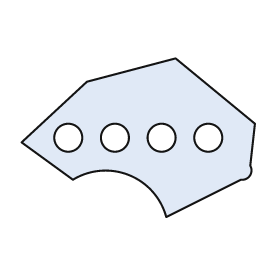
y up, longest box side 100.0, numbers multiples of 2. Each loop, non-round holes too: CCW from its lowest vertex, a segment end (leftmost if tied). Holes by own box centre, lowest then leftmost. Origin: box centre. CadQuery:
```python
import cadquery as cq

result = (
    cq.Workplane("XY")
    .moveTo(12.0, -34.0)
    .lineTo(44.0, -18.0)
    .threePointArc((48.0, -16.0), (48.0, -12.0))
    .lineTo(50.0, 6.0)
    .lineTo(16.0, 34.0)
    .lineTo(-22.0, 24.0)
    .lineTo(-50.0, -2.0)
    .lineTo(-28.0, -18.0)
    .threePointArc((-4.0, -16.0), (12.0, -34.0))
    .close()
    .moveTo(-30.0, 0.0)
    .circle(6.0)
    .moveTo(-10.0, 0.0)
    .circle(6.0)
    .moveTo(10.0, 0.0)
    .circle(6.0)
    .moveTo(30.0, 0.0)
    .circle(6.0)
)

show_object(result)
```